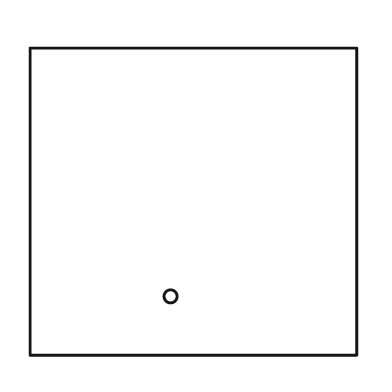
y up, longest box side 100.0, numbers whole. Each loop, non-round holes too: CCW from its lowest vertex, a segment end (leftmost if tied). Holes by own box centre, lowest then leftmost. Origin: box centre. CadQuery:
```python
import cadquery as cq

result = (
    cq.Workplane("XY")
    .moveTo(-50.0, -47.0)
    .lineTo(50.0, -47.0)
    .lineTo(50.0, 47.0)
    .lineTo(-50.0, 47.0)
    .close()
    .moveTo(-7.0, -29.0)
    .circle(2.0)
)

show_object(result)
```